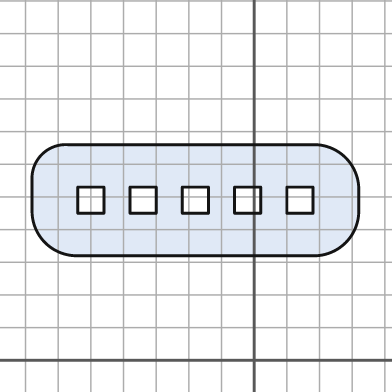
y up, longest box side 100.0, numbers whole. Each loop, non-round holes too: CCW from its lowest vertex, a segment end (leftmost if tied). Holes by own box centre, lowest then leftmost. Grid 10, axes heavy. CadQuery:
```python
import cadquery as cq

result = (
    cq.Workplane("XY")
    .moveTo(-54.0, 32.0)
    .lineTo(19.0, 32.0)
    .threePointArc((28.0, 36.0), (32.0, 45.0))
    .lineTo(32.0, 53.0)
    .threePointArc((28.0, 62.0), (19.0, 66.0))
    .lineTo(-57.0, 66.0)
    .threePointArc((-65.0, 63.0), (-68.0, 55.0))
    .lineTo(-68.0, 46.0)
    .threePointArc((-64.0, 36.0), (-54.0, 32.0))
    .close()
    .moveTo(-54.0, 45.0)
    .lineTo(-46.0, 45.0)
    .lineTo(-46.0, 53.0)
    .lineTo(-54.0, 53.0)
    .close()
    .moveTo(-38.0, 45.0)
    .lineTo(-30.0, 45.0)
    .lineTo(-30.0, 53.0)
    .lineTo(-38.0, 53.0)
    .close()
    .moveTo(-22.0, 45.0)
    .lineTo(-14.0, 45.0)
    .lineTo(-14.0, 53.0)
    .lineTo(-22.0, 53.0)
    .close()
    .moveTo(-6.0, 45.0)
    .lineTo(2.0, 45.0)
    .lineTo(2.0, 53.0)
    .lineTo(-6.0, 53.0)
    .close()
    .moveTo(10.0, 45.0)
    .lineTo(18.0, 45.0)
    .lineTo(18.0, 53.0)
    .lineTo(10.0, 53.0)
    .close()
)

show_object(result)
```